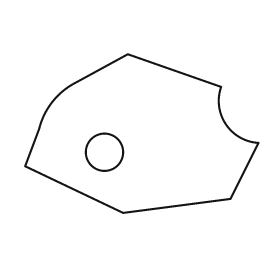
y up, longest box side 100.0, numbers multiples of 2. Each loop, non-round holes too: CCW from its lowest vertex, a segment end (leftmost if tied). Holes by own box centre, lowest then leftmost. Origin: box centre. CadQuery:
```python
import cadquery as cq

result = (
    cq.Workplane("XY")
    .moveTo(-8.0, -34.0)
    .lineTo(38.0, -28.0)
    .lineTo(50.0, -4.0)
    .threePointArc((36.0, 4.0), (34.0, 20.0))
    .lineTo(-6.0, 34.0)
    .lineTo(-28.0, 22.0)
    .threePointArc((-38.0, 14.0), (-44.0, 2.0))
    .lineTo(-50.0, -14.0)
    .close()
    .moveTo(-16.0, -8.0)
    .circle(8.0)
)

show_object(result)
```